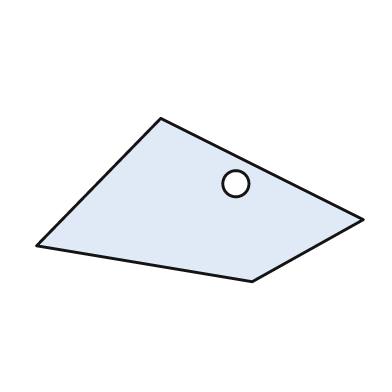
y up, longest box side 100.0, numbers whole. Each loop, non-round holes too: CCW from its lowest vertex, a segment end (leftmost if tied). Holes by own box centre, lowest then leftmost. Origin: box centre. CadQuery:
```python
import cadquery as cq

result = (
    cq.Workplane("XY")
    .moveTo(16.0, -25.0)
    .lineTo(50.0, -6.0)
    .lineTo(-12.0, 25.0)
    .lineTo(-50.0, -14.0)
    .close()
    .moveTo(11.0, 5.0)
    .circle(4.0)
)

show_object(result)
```